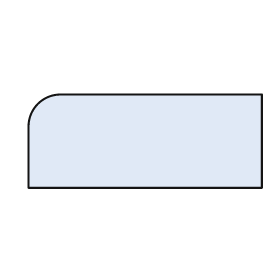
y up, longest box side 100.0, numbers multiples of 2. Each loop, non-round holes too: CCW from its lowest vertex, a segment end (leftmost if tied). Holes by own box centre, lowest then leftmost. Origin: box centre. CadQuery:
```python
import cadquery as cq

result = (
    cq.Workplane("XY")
    .moveTo(-50.0, -20.0)
    .lineTo(50.0, -20.0)
    .lineTo(50.0, 20.0)
    .lineTo(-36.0, 20.0)
    .threePointArc((-46.0, 16.0), (-50.0, 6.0))
    .close()
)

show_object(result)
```